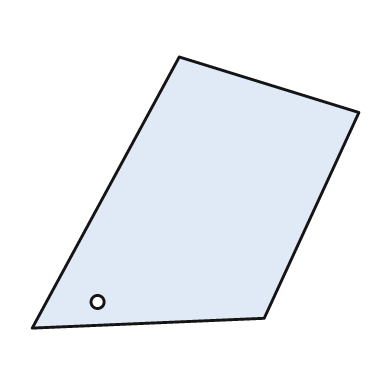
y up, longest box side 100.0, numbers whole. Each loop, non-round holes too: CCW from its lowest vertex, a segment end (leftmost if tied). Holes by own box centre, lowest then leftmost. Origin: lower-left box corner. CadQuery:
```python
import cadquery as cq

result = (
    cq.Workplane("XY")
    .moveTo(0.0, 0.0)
    .lineTo(71.0, 3.0)
    .lineTo(100.0, 66.0)
    .lineTo(45.0, 83.0)
    .close()
    .moveTo(20.0, 8.0)
    .circle(2.0)
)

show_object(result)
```